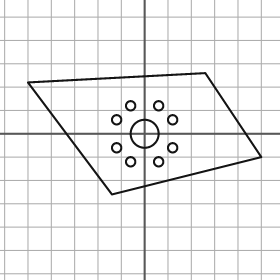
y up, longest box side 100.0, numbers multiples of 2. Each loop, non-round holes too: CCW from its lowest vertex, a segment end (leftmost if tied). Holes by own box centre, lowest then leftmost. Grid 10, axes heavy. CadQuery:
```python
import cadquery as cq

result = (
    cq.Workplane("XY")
    .moveTo(-14.0, -26.0)
    .lineTo(50.0, -10.0)
    .lineTo(26.0, 26.0)
    .lineTo(-50.0, 22.0)
    .close()
    .moveTo(-6.0, -12.0)
    .circle(2.0)
    .moveTo(6.0, -12.0)
    .circle(2.0)
    .moveTo(-12.0, -6.0)
    .circle(2.0)
    .moveTo(12.0, -6.0)
    .circle(2.0)
    .moveTo(0.0, 0.0)
    .circle(6.0)
    .moveTo(-12.0, 6.0)
    .circle(2.0)
    .moveTo(12.0, 6.0)
    .circle(2.0)
    .moveTo(-6.0, 12.0)
    .circle(2.0)
    .moveTo(6.0, 12.0)
    .circle(2.0)
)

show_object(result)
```